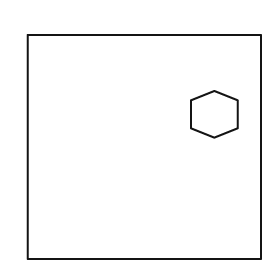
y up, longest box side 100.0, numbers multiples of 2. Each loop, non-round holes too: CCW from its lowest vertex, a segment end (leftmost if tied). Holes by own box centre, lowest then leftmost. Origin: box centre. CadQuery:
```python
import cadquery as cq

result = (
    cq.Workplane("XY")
    .moveTo(-50.0, -48.0)
    .lineTo(50.0, -48.0)
    .lineTo(50.0, 48.0)
    .lineTo(-50.0, 48.0)
    .close()
    .moveTo(30.0, 4.0)
    .lineTo(40.0, 8.0)
    .lineTo(40.0, 20.0)
    .lineTo(30.0, 24.0)
    .lineTo(20.0, 20.0)
    .lineTo(20.0, 8.0)
    .close()
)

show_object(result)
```